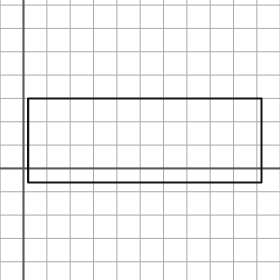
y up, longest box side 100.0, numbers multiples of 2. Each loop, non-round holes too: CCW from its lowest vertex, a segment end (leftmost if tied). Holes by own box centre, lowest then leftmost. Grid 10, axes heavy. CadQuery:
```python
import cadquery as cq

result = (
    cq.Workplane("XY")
    .moveTo(2.0, -6.0)
    .lineTo(102.0, -6.0)
    .lineTo(102.0, 30.0)
    .lineTo(2.0, 30.0)
    .close()
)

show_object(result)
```